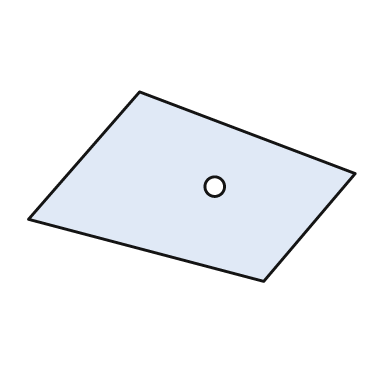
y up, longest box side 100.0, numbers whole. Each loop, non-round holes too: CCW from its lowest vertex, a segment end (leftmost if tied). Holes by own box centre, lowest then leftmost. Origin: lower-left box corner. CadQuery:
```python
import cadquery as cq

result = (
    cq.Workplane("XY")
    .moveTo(72.0, 0.0)
    .lineTo(100.0, 33.0)
    .lineTo(34.0, 58.0)
    .lineTo(0.0, 19.0)
    .close()
    .moveTo(57.0, 29.0)
    .circle(3.0)
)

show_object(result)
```